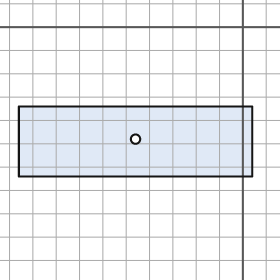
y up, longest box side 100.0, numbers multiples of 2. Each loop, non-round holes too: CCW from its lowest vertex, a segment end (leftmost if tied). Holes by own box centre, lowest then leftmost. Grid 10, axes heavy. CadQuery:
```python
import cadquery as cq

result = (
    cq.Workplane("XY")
    .moveTo(-96.0, -64.0)
    .lineTo(4.0, -64.0)
    .lineTo(4.0, -34.0)
    .lineTo(-96.0, -34.0)
    .close()
    .moveTo(-46.0, -48.0)
    .circle(2.0)
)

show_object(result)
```